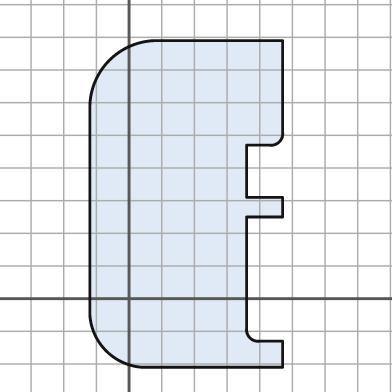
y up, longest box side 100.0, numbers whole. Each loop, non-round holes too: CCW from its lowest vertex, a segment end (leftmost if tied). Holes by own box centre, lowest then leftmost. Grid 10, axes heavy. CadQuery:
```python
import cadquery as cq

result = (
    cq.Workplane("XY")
    .moveTo(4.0, -21.0)
    .lineTo(47.0, -21.0)
    .lineTo(47.0, -13.0)
    .lineTo(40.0, -13.0)
    .threePointArc((37.0, -12.0), (36.0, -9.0))
    .lineTo(36.0, 25.0)
    .lineTo(47.0, 25.0)
    .lineTo(47.0, 31.0)
    .lineTo(36.0, 31.0)
    .lineTo(36.0, 47.0)
    .lineTo(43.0, 47.0)
    .threePointArc((46.0, 48.0), (47.0, 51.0))
    .lineTo(47.0, 79.0)
    .lineTo(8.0, 79.0)
    .threePointArc((-6.0, 73.0), (-12.0, 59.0))
    .lineTo(-12.0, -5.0)
    .threePointArc((-7.0, -16.0), (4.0, -21.0))
    .close()
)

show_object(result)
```